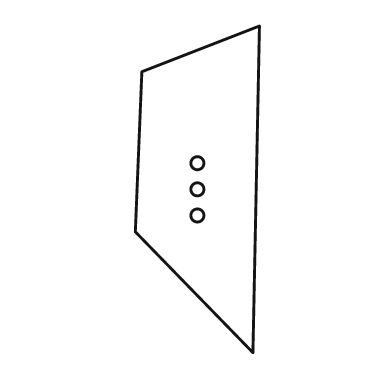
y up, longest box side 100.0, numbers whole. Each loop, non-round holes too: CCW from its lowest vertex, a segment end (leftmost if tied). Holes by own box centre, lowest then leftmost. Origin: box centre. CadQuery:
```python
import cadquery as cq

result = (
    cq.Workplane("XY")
    .moveTo(17.0, -50.0)
    .lineTo(19.0, 50.0)
    .lineTo(-17.0, 36.0)
    .lineTo(-19.0, -13.0)
    .close()
    .moveTo(0.0, -8.0)
    .circle(2.0)
    .moveTo(0.0, 0.0)
    .circle(2.0)
    .moveTo(0.0, 8.0)
    .circle(2.0)
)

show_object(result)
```